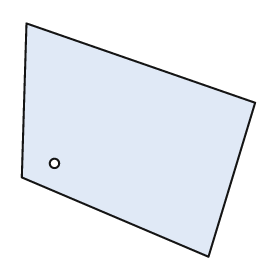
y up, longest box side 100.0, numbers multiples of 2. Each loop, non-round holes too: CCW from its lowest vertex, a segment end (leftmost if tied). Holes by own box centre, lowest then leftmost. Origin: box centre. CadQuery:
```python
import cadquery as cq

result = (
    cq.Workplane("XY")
    .moveTo(30.0, -50.0)
    .lineTo(50.0, 16.0)
    .lineTo(-48.0, 50.0)
    .lineTo(-50.0, -16.0)
    .close()
    .moveTo(-36.0, -10.0)
    .circle(2.0)
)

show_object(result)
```